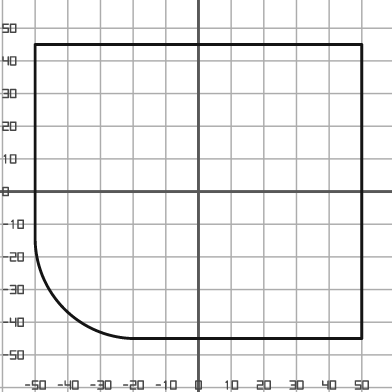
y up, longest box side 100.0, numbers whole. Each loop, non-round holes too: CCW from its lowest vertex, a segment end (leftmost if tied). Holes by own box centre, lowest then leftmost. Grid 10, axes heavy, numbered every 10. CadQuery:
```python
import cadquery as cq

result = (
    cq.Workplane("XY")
    .moveTo(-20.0, -45.0)
    .lineTo(50.0, -45.0)
    .lineTo(50.0, 45.0)
    .lineTo(-50.0, 45.0)
    .lineTo(-50.0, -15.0)
    .threePointArc((-41.0, -36.0), (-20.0, -45.0))
    .close()
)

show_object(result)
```